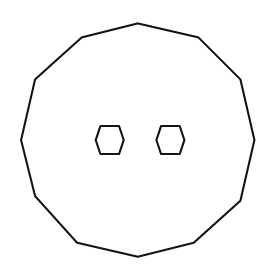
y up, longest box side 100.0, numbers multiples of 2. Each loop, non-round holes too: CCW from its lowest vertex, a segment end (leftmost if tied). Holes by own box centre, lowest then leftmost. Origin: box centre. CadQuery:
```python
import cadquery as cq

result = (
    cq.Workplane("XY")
    .moveTo(0.0, -50.0)
    .lineTo(24.0, -44.0)
    .lineTo(44.0, -26.0)
    .lineTo(50.0, 0.0)
    .lineTo(44.0, 26.0)
    .lineTo(26.0, 44.0)
    .lineTo(0.0, 50.0)
    .lineTo(-24.0, 44.0)
    .lineTo(-44.0, 26.0)
    .lineTo(-50.0, 0.0)
    .lineTo(-44.0, -24.0)
    .lineTo(-26.0, -44.0)
    .close()
    .moveTo(-16.0, -6.0)
    .lineTo(-8.0, -6.0)
    .lineTo(-6.0, 0.0)
    .lineTo(-8.0, 6.0)
    .lineTo(-16.0, 6.0)
    .lineTo(-18.0, 0.0)
    .close()
    .moveTo(10.0, -6.0)
    .lineTo(18.0, -6.0)
    .lineTo(20.0, 0.0)
    .lineTo(18.0, 6.0)
    .lineTo(10.0, 6.0)
    .lineTo(8.0, 0.0)
    .close()
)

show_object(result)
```